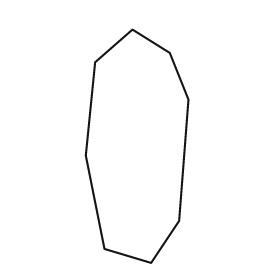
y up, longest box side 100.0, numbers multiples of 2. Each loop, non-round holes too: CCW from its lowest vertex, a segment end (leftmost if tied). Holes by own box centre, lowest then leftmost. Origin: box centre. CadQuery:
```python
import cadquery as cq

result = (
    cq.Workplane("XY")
    .moveTo(6.0, -50.0)
    .lineTo(18.0, -32.0)
    .lineTo(22.0, 20.0)
    .lineTo(14.0, 40.0)
    .lineTo(-2.0, 50.0)
    .lineTo(-18.0, 36.0)
    .lineTo(-22.0, -4.0)
    .lineTo(-14.0, -44.0)
    .close()
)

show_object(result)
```